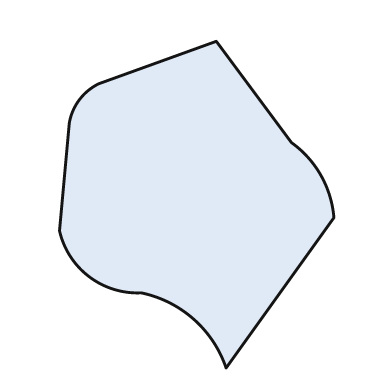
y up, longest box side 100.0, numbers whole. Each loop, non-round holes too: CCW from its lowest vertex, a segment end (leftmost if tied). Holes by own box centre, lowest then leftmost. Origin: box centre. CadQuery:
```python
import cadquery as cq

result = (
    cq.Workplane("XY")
    .moveTo(9.0, -50.0)
    .lineTo(42.0, -4.0)
    .threePointArc((38.0, 9.0), (29.0, 19.0))
    .lineTo(6.0, 50.0)
    .lineTo(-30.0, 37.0)
    .threePointArc((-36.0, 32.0), (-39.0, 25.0))
    .lineTo(-42.0, -8.0)
    .threePointArc((-33.0, -22.0), (-17.0, -27.0))
    .threePointArc((-1.0, -35.0), (9.0, -50.0))
    .close()
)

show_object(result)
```